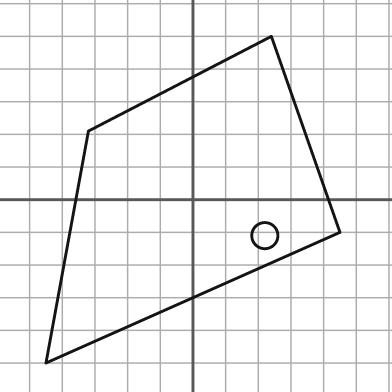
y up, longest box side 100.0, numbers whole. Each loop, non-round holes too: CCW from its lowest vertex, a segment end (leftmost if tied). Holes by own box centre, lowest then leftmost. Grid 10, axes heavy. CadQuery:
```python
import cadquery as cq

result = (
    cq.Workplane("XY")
    .moveTo(-45.0, -50.0)
    .lineTo(45.0, -10.0)
    .lineTo(24.0, 50.0)
    .lineTo(-32.0, 21.0)
    .close()
    .moveTo(22.0, -11.0)
    .circle(4.0)
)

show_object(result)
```